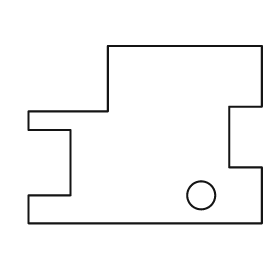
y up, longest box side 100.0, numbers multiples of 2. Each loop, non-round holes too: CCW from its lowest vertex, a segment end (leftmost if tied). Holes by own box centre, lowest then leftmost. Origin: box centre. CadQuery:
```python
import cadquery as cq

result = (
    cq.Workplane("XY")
    .moveTo(-50.0, -38.0)
    .lineTo(50.0, -38.0)
    .lineTo(50.0, -14.0)
    .lineTo(36.0, -14.0)
    .lineTo(36.0, 12.0)
    .lineTo(50.0, 12.0)
    .lineTo(50.0, 38.0)
    .lineTo(-16.0, 38.0)
    .lineTo(-16.0, 10.0)
    .lineTo(-50.0, 10.0)
    .lineTo(-50.0, 2.0)
    .lineTo(-32.0, 2.0)
    .lineTo(-32.0, -26.0)
    .lineTo(-50.0, -26.0)
    .close()
    .moveTo(24.0, -26.0)
    .circle(6.0)
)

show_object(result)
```